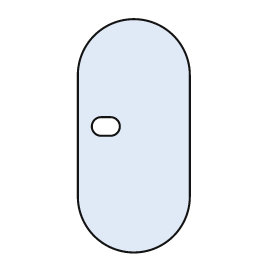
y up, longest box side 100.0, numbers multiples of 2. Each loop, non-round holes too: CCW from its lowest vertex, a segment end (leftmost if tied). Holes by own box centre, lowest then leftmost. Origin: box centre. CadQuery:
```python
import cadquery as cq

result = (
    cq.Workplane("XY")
    .moveTo(-24.0, -26.0)
    .threePointArc((0.0, -50.0), (24.0, -26.0))
    .lineTo(24.0, 26.0)
    .threePointArc((0.0, 50.0), (-24.0, 26.0))
    .close()
    .moveTo(-14.0, 0.0)
    .lineTo(-10.0, 0.0)
    .threePointArc((-6.0, 4.0), (-10.0, 8.0))
    .lineTo(-14.0, 8.0)
    .threePointArc((-18.0, 4.0), (-14.0, 0.0))
    .close()
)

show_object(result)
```